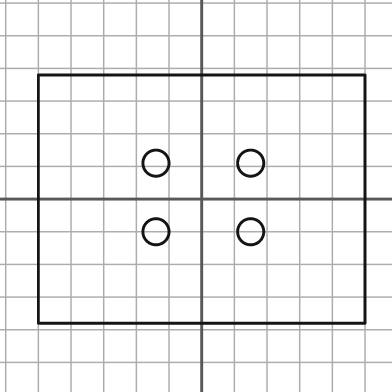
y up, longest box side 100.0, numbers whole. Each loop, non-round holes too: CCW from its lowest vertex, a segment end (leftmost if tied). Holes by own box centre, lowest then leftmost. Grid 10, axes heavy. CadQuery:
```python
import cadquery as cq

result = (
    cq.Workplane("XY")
    .moveTo(-50.0, -38.0)
    .lineTo(50.0, -38.0)
    .lineTo(50.0, 38.0)
    .lineTo(-50.0, 38.0)
    .close()
    .moveTo(-14.0, -10.0)
    .circle(4.0)
    .moveTo(15.0, -10.0)
    .circle(4.0)
    .moveTo(-14.0, 11.0)
    .circle(4.0)
    .moveTo(15.0, 11.0)
    .circle(4.0)
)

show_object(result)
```